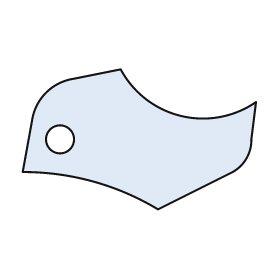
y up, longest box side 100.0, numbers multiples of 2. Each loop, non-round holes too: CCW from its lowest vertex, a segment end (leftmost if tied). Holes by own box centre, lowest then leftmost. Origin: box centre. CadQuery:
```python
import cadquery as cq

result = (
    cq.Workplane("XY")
    .moveTo(8.0, -30.0)
    .lineTo(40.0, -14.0)
    .threePointArc((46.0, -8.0), (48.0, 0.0))
    .lineTo(50.0, 16.0)
    .threePointArc((18.0, 10.0), (-8.0, 30.0))
    .lineTo(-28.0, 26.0)
    .threePointArc((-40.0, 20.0), (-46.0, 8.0))
    .lineTo(-50.0, -14.0)
    .threePointArc((-20.0, -18.0), (8.0, -30.0))
    .close()
    .moveTo(-34.0, 0.0)
    .circle(6.0)
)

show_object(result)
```